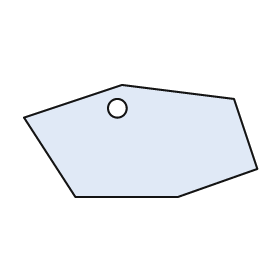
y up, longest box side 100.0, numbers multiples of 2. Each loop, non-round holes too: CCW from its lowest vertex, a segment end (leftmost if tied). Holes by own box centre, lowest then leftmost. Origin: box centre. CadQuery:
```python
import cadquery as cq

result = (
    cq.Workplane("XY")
    .moveTo(-28.0, -24.0)
    .lineTo(16.0, -24.0)
    .lineTo(50.0, -12.0)
    .lineTo(40.0, 18.0)
    .lineTo(-8.0, 24.0)
    .lineTo(-50.0, 10.0)
    .close()
    .moveTo(-10.0, 14.0)
    .circle(4.0)
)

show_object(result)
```